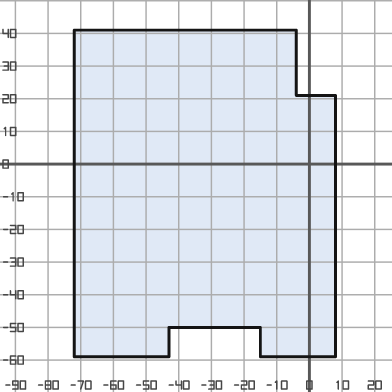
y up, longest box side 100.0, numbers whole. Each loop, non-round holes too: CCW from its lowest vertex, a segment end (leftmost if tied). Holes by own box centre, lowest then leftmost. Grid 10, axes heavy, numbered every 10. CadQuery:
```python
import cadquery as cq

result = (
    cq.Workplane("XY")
    .moveTo(-72.0, -59.0)
    .lineTo(-43.0, -59.0)
    .lineTo(-43.0, -50.0)
    .lineTo(-15.0, -50.0)
    .lineTo(-15.0, -59.0)
    .lineTo(8.0, -59.0)
    .lineTo(8.0, 21.0)
    .lineTo(-4.0, 21.0)
    .lineTo(-4.0, 41.0)
    .lineTo(-72.0, 41.0)
    .close()
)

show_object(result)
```